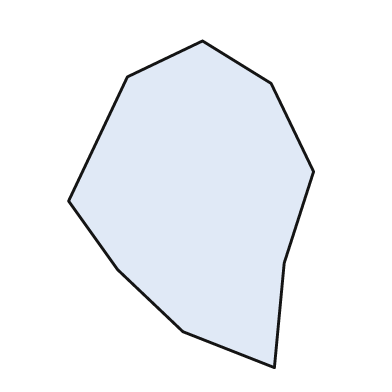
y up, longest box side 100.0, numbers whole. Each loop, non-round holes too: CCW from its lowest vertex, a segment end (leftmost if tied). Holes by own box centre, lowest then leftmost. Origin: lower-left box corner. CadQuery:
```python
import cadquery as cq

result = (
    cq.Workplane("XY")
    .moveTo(63.0, 0.0)
    .lineTo(66.0, 32.0)
    .lineTo(75.0, 60.0)
    .lineTo(62.0, 87.0)
    .lineTo(41.0, 100.0)
    .lineTo(18.0, 89.0)
    .lineTo(0.0, 51.0)
    .lineTo(15.0, 30.0)
    .lineTo(35.0, 11.0)
    .close()
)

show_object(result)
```